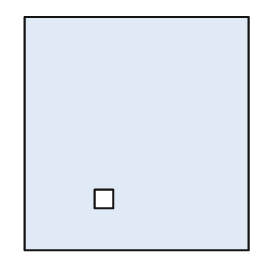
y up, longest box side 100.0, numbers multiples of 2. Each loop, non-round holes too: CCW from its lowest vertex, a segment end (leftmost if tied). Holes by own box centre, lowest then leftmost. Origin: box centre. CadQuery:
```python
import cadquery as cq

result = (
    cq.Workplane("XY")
    .moveTo(-48.0, -50.0)
    .lineTo(48.0, -50.0)
    .lineTo(48.0, 50.0)
    .lineTo(-48.0, 50.0)
    .close()
    .moveTo(-18.0, -32.0)
    .lineTo(-10.0, -32.0)
    .lineTo(-10.0, -24.0)
    .lineTo(-18.0, -24.0)
    .close()
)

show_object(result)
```